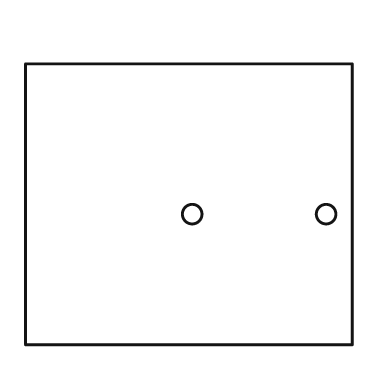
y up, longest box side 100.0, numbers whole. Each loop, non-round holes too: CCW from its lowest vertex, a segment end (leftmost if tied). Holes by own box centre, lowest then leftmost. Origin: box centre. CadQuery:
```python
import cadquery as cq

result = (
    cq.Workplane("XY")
    .moveTo(-50.0, -43.0)
    .lineTo(50.0, -43.0)
    .lineTo(50.0, 43.0)
    .lineTo(-50.0, 43.0)
    .close()
    .moveTo(1.0, -3.0)
    .circle(3.0)
    .moveTo(42.0, -3.0)
    .circle(3.0)
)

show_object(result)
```